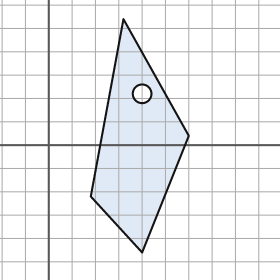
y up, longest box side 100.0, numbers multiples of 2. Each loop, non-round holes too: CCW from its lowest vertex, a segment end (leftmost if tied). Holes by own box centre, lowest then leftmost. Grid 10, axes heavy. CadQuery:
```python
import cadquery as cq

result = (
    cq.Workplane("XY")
    .moveTo(40.0, -46.0)
    .lineTo(60.0, 4.0)
    .lineTo(32.0, 54.0)
    .lineTo(18.0, -22.0)
    .close()
    .moveTo(40.0, 22.0)
    .circle(4.0)
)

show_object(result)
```